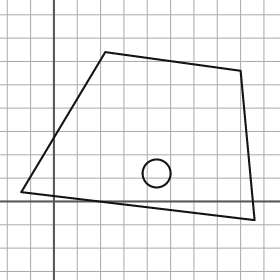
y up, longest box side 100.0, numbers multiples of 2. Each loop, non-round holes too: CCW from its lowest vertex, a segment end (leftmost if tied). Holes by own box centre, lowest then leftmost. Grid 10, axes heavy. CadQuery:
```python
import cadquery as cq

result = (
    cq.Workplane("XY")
    .moveTo(86.0, -8.0)
    .lineTo(80.0, 56.0)
    .lineTo(22.0, 64.0)
    .lineTo(-14.0, 4.0)
    .close()
    .moveTo(44.0, 12.0)
    .circle(6.0)
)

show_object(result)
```